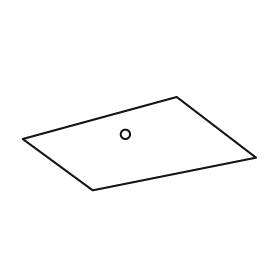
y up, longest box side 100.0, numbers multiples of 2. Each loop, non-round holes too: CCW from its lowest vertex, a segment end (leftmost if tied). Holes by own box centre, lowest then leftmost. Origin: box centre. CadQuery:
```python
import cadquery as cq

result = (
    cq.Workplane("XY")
    .moveTo(-20.0, -20.0)
    .lineTo(50.0, -6.0)
    .lineTo(16.0, 20.0)
    .lineTo(-50.0, 2.0)
    .close()
    .moveTo(-6.0, 4.0)
    .circle(2.0)
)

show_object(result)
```